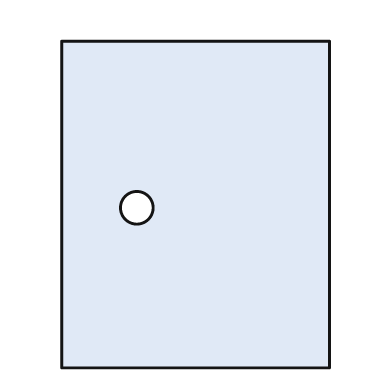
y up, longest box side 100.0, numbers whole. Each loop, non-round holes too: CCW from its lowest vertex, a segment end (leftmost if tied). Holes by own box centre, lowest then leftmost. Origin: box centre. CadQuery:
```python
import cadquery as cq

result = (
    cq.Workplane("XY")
    .moveTo(-41.0, -50.0)
    .lineTo(41.0, -50.0)
    .lineTo(41.0, 50.0)
    .lineTo(-41.0, 50.0)
    .close()
    .moveTo(-18.0, -1.0)
    .circle(5.0)
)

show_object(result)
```